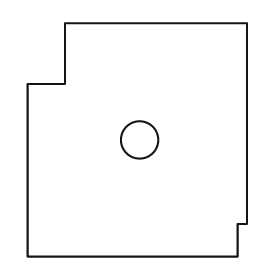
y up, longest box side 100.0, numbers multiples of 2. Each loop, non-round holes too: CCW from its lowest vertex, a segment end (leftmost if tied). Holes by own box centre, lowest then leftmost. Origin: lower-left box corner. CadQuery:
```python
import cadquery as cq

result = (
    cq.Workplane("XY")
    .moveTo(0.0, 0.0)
    .lineTo(90.0, 0.0)
    .lineTo(90.0, 14.0)
    .lineTo(94.0, 14.0)
    .lineTo(94.0, 100.0)
    .lineTo(16.0, 100.0)
    .lineTo(16.0, 74.0)
    .lineTo(0.0, 74.0)
    .close()
    .moveTo(48.0, 50.0)
    .circle(8.0)
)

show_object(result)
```